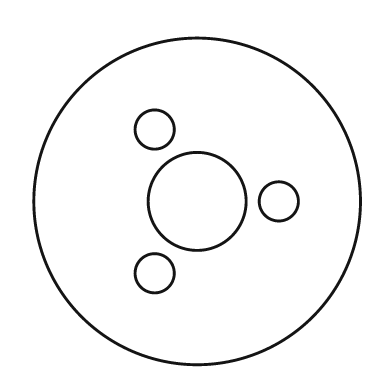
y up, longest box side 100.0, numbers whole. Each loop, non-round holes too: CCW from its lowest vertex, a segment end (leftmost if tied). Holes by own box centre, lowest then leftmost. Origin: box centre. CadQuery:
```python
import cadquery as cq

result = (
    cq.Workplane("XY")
    .moveTo(0.0, 0.0)
    .circle(50.0)
    .moveTo(-13.0, -22.0)
    .circle(6.0)
    .moveTo(0.0, 0.0)
    .circle(15.0)
    .moveTo(25.0, 0.0)
    .circle(6.0)
    .moveTo(-13.0, 22.0)
    .circle(6.0)
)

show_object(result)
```